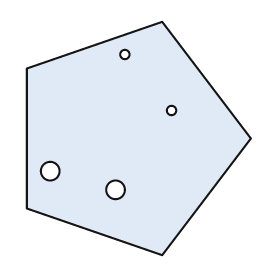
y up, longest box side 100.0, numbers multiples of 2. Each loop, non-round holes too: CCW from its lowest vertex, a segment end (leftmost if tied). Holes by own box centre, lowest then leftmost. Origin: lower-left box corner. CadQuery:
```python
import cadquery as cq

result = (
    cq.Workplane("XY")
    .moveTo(58.0, 0.0)
    .lineTo(96.0, 50.0)
    .lineTo(58.0, 100.0)
    .lineTo(0.0, 80.0)
    .lineTo(0.0, 20.0)
    .close()
    .moveTo(38.0, 28.0)
    .circle(4.0)
    .moveTo(10.0, 36.0)
    .circle(4.0)
    .moveTo(62.0, 62.0)
    .circle(2.0)
    .moveTo(42.0, 86.0)
    .circle(2.0)
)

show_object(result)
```